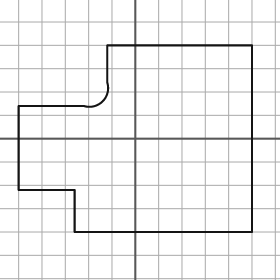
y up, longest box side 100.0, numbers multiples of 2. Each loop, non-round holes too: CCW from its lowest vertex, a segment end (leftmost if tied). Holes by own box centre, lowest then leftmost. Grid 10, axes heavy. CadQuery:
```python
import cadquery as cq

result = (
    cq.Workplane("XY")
    .moveTo(-26.0, -40.0)
    .lineTo(50.0, -40.0)
    .lineTo(50.0, 40.0)
    .lineTo(-12.0, 40.0)
    .lineTo(-12.0, 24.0)
    .threePointArc((-14.0, 16.0), (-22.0, 14.0))
    .lineTo(-50.0, 14.0)
    .lineTo(-50.0, -22.0)
    .lineTo(-26.0, -22.0)
    .close()
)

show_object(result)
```